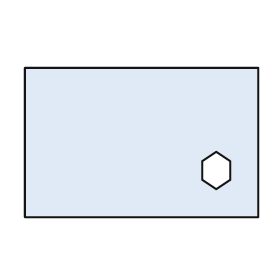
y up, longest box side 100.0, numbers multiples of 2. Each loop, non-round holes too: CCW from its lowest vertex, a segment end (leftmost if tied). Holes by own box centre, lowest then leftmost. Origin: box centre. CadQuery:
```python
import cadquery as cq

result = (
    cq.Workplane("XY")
    .moveTo(-50.0, -32.0)
    .lineTo(50.0, -32.0)
    .lineTo(50.0, 32.0)
    .lineTo(-50.0, 32.0)
    .close()
    .moveTo(32.0, -20.0)
    .lineTo(38.0, -16.0)
    .lineTo(38.0, -8.0)
    .lineTo(32.0, -4.0)
    .lineTo(26.0, -8.0)
    .lineTo(26.0, -16.0)
    .close()
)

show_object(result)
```